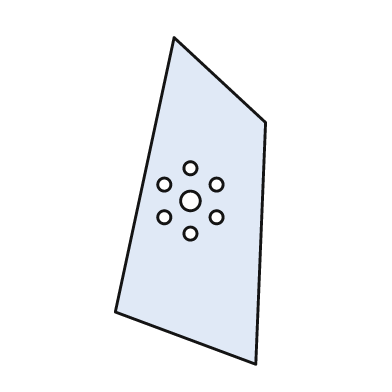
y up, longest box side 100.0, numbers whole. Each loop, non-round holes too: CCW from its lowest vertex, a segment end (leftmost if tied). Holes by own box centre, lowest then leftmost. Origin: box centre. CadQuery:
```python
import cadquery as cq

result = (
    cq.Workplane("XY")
    .moveTo(20.0, -50.0)
    .lineTo(23.0, 24.0)
    .lineTo(-5.0, 50.0)
    .lineTo(-23.0, -34.0)
    .close()
    .moveTo(0.0, -10.0)
    .circle(2.0)
    .moveTo(-8.0, -5.0)
    .circle(2.0)
    .moveTo(8.0, -5.0)
    .circle(2.0)
    .moveTo(0.0, 0.0)
    .circle(3.0)
    .moveTo(-8.0, 5.0)
    .circle(2.0)
    .moveTo(8.0, 5.0)
    .circle(2.0)
    .moveTo(0.0, 10.0)
    .circle(2.0)
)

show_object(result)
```